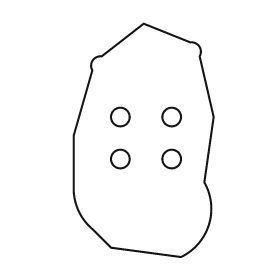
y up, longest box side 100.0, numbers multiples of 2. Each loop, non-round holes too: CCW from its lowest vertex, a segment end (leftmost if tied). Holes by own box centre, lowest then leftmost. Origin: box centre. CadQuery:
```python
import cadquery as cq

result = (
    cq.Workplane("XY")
    .moveTo(16.0, -50.0)
    .threePointArc((28.0, -36.0), (26.0, -18.0))
    .lineTo(30.0, 10.0)
    .lineTo(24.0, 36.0)
    .threePointArc((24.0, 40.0), (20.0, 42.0))
    .lineTo(0.0, 50.0)
    .lineTo(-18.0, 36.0)
    .threePointArc((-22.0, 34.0), (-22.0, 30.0))
    .lineTo(-30.0, 2.0)
    .lineTo(-30.0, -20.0)
    .threePointArc((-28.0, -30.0), (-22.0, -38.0))
    .lineTo(-14.0, -46.0)
    .close()
    .moveTo(-10.0, -8.0)
    .circle(4.0)
    .moveTo(12.0, -8.0)
    .circle(4.0)
    .moveTo(-10.0, 10.0)
    .circle(4.0)
    .moveTo(12.0, 10.0)
    .circle(4.0)
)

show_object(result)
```